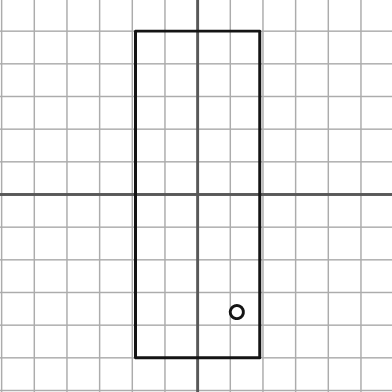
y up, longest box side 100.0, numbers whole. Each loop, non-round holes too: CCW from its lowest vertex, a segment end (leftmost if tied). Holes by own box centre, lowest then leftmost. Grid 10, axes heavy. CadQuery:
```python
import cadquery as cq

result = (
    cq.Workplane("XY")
    .moveTo(-19.0, -50.0)
    .lineTo(19.0, -50.0)
    .lineTo(19.0, 50.0)
    .lineTo(-19.0, 50.0)
    .close()
    .moveTo(12.0, -36.0)
    .circle(2.0)
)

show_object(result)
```